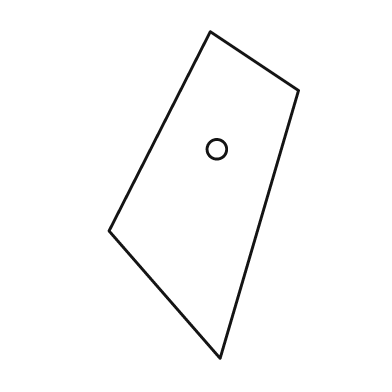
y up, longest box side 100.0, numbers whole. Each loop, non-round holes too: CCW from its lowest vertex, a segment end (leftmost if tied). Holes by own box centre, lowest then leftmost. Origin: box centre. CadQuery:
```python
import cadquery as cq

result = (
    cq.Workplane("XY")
    .moveTo(5.0, -50.0)
    .lineTo(29.0, 32.0)
    .lineTo(2.0, 50.0)
    .lineTo(-29.0, -11.0)
    .close()
    .moveTo(4.0, 14.0)
    .circle(3.0)
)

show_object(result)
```